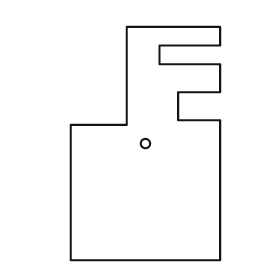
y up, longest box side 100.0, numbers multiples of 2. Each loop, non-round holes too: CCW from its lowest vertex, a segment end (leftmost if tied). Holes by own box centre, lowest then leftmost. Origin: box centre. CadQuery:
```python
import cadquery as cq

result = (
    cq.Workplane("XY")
    .moveTo(-32.0, -50.0)
    .lineTo(32.0, -50.0)
    .lineTo(32.0, 10.0)
    .lineTo(14.0, 10.0)
    .lineTo(14.0, 22.0)
    .lineTo(32.0, 22.0)
    .lineTo(32.0, 34.0)
    .lineTo(6.0, 34.0)
    .lineTo(6.0, 42.0)
    .lineTo(32.0, 42.0)
    .lineTo(32.0, 50.0)
    .lineTo(-8.0, 50.0)
    .lineTo(-8.0, 8.0)
    .lineTo(-32.0, 8.0)
    .close()
    .moveTo(0.0, 0.0)
    .circle(2.0)
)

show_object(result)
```